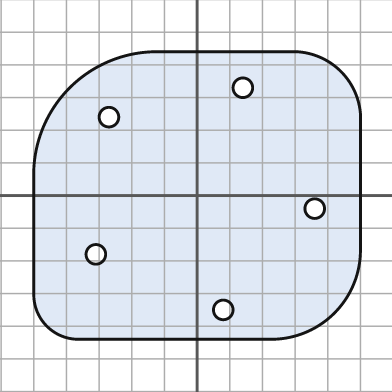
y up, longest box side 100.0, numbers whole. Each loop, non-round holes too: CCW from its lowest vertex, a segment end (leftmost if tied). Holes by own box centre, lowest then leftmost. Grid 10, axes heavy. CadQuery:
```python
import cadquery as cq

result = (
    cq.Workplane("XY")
    .moveTo(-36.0, -44.0)
    .lineTo(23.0, -44.0)
    .threePointArc((42.0, -36.0), (50.0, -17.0))
    .lineTo(50.0, 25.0)
    .threePointArc((44.0, 38.0), (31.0, 44.0))
    .lineTo(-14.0, 44.0)
    .threePointArc((-39.0, 33.0), (-50.0, 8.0))
    .lineTo(-50.0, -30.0)
    .threePointArc((-46.0, -40.0), (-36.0, -44.0))
    .close()
    .moveTo(8.0, -35.0)
    .circle(3.0)
    .moveTo(-31.0, -18.0)
    .circle(3.0)
    .moveTo(36.0, -4.0)
    .circle(3.0)
    .moveTo(-27.0, 24.0)
    .circle(3.0)
    .moveTo(14.0, 33.0)
    .circle(3.0)
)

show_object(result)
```